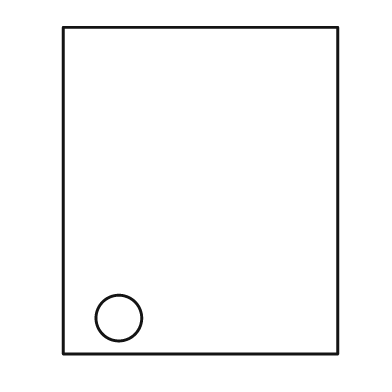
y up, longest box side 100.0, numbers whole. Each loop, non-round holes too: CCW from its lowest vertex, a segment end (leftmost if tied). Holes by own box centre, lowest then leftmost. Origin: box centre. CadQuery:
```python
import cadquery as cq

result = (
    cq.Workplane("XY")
    .moveTo(-42.0, -50.0)
    .lineTo(42.0, -50.0)
    .lineTo(42.0, 50.0)
    .lineTo(-42.0, 50.0)
    .close()
    .moveTo(-25.0, -39.0)
    .circle(7.0)
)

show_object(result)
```